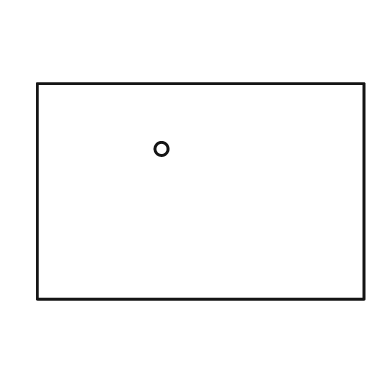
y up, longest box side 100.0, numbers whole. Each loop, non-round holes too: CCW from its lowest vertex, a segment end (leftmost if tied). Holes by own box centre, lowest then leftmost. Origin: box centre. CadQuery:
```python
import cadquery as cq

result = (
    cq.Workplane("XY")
    .moveTo(-50.0, -33.0)
    .lineTo(50.0, -33.0)
    .lineTo(50.0, 33.0)
    .lineTo(-50.0, 33.0)
    .close()
    .moveTo(-12.0, 13.0)
    .circle(2.0)
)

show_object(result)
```